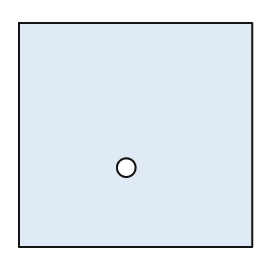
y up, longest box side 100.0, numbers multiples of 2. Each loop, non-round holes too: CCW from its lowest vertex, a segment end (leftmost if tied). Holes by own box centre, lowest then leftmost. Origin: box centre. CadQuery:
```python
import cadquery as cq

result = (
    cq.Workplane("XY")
    .moveTo(-50.0, -48.0)
    .lineTo(50.0, -48.0)
    .lineTo(50.0, 48.0)
    .lineTo(-50.0, 48.0)
    .close()
    .moveTo(-4.0, -14.0)
    .circle(4.0)
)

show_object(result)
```